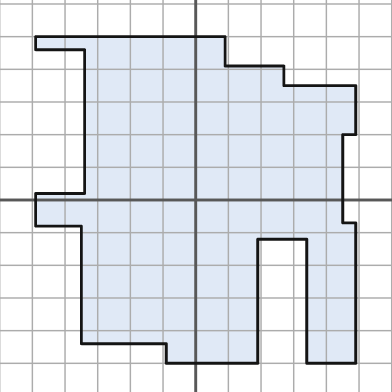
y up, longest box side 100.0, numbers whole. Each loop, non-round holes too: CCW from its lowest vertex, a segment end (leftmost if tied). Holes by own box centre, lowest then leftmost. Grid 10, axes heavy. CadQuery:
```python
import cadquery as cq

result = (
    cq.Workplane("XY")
    .moveTo(-9.0, -50.0)
    .lineTo(19.0, -50.0)
    .lineTo(19.0, -12.0)
    .lineTo(34.0, -12.0)
    .lineTo(34.0, -50.0)
    .lineTo(49.0, -50.0)
    .lineTo(49.0, -7.0)
    .lineTo(45.0, -7.0)
    .lineTo(45.0, 20.0)
    .lineTo(49.0, 20.0)
    .lineTo(49.0, 35.0)
    .lineTo(27.0, 35.0)
    .lineTo(27.0, 41.0)
    .lineTo(9.0, 41.0)
    .lineTo(9.0, 50.0)
    .lineTo(-49.0, 50.0)
    .lineTo(-49.0, 46.0)
    .lineTo(-34.0, 46.0)
    .lineTo(-34.0, 2.0)
    .lineTo(-49.0, 2.0)
    .lineTo(-49.0, -8.0)
    .lineTo(-35.0, -8.0)
    .lineTo(-35.0, -44.0)
    .lineTo(-9.0, -44.0)
    .close()
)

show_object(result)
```